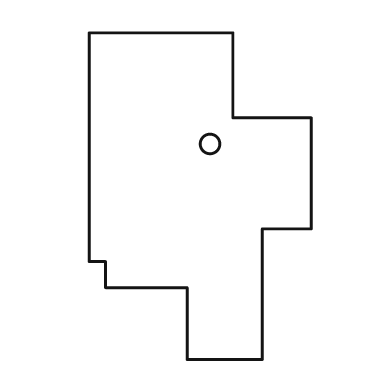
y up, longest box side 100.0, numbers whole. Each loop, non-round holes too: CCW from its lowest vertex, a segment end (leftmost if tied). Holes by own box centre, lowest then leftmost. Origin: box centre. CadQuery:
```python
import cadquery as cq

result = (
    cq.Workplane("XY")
    .moveTo(-4.0, -50.0)
    .lineTo(19.0, -50.0)
    .lineTo(19.0, -10.0)
    .lineTo(34.0, -10.0)
    .lineTo(34.0, 24.0)
    .lineTo(10.0, 24.0)
    .lineTo(10.0, 50.0)
    .lineTo(-34.0, 50.0)
    .lineTo(-34.0, -20.0)
    .lineTo(-29.0, -20.0)
    .lineTo(-29.0, -28.0)
    .lineTo(-4.0, -28.0)
    .close()
    .moveTo(3.0, 16.0)
    .circle(3.0)
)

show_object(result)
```